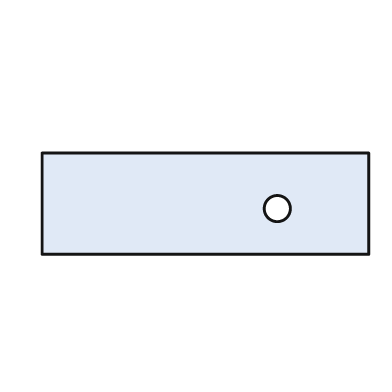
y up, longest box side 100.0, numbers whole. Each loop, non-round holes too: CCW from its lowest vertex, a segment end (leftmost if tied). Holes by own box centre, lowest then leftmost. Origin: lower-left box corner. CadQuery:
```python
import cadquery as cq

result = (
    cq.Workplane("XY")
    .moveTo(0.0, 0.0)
    .lineTo(100.0, 0.0)
    .lineTo(100.0, 31.0)
    .lineTo(0.0, 31.0)
    .close()
    .moveTo(72.0, 14.0)
    .circle(4.0)
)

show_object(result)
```